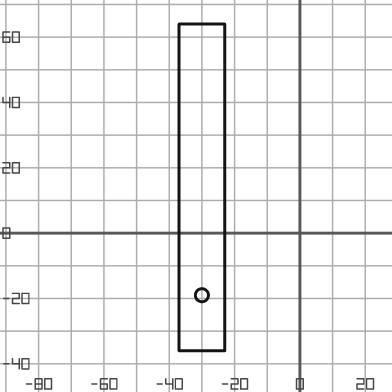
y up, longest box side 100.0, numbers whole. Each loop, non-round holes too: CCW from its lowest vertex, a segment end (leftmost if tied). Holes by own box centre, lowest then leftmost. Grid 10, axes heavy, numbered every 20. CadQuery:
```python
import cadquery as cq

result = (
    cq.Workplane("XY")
    .moveTo(-37.0, -36.0)
    .lineTo(-23.0, -36.0)
    .lineTo(-23.0, 64.0)
    .lineTo(-37.0, 64.0)
    .close()
    .moveTo(-30.0, -19.0)
    .circle(2.0)
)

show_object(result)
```